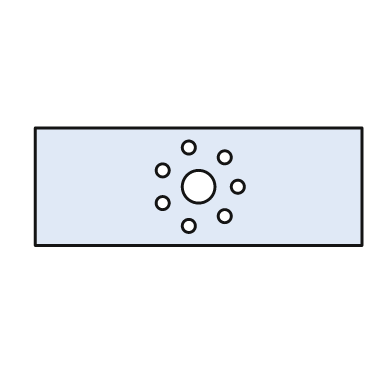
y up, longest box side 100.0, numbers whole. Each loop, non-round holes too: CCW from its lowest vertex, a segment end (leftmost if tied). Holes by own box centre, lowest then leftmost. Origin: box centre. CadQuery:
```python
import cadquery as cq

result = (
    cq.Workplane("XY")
    .moveTo(-50.0, -18.0)
    .lineTo(50.0, -18.0)
    .lineTo(50.0, 18.0)
    .lineTo(-50.0, 18.0)
    .close()
    .moveTo(-3.0, -12.0)
    .circle(2.0)
    .moveTo(8.0, -9.0)
    .circle(2.0)
    .moveTo(-11.0, -5.0)
    .circle(2.0)
    .moveTo(0.0, 0.0)
    .circle(5.0)
    .moveTo(12.0, 0.0)
    .circle(2.0)
    .moveTo(-11.0, 5.0)
    .circle(2.0)
    .moveTo(8.0, 9.0)
    .circle(2.0)
    .moveTo(-3.0, 12.0)
    .circle(2.0)
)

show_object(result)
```